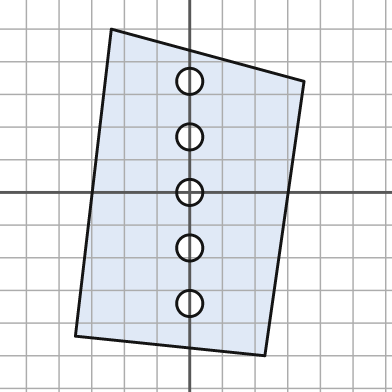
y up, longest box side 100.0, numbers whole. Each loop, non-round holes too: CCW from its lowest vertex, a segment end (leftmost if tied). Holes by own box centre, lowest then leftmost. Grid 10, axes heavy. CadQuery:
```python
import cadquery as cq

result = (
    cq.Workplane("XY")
    .moveTo(23.0, -50.0)
    .lineTo(35.0, 34.0)
    .lineTo(-24.0, 50.0)
    .lineTo(-35.0, -44.0)
    .close()
    .moveTo(0.0, -34.0)
    .circle(4.0)
    .moveTo(0.0, -17.0)
    .circle(4.0)
    .moveTo(0.0, 0.0)
    .circle(4.0)
    .moveTo(0.0, 17.0)
    .circle(4.0)
    .moveTo(0.0, 34.0)
    .circle(4.0)
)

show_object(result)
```